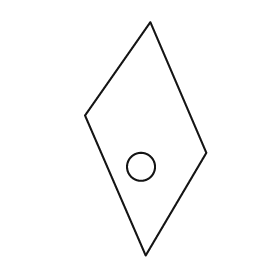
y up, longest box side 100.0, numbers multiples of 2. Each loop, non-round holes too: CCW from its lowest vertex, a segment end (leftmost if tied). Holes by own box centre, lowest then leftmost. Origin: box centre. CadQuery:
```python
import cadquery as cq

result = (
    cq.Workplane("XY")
    .moveTo(0.0, -50.0)
    .lineTo(26.0, -6.0)
    .lineTo(2.0, 50.0)
    .lineTo(-26.0, 10.0)
    .close()
    .moveTo(-2.0, -12.0)
    .circle(6.0)
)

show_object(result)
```